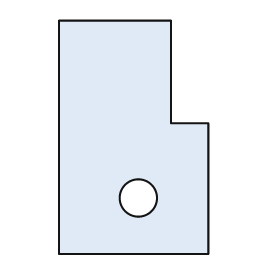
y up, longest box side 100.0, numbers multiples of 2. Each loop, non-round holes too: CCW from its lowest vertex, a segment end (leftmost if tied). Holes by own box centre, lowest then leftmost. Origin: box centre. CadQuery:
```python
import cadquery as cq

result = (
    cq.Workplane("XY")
    .moveTo(-32.0, -50.0)
    .lineTo(32.0, -50.0)
    .lineTo(32.0, 6.0)
    .lineTo(16.0, 6.0)
    .lineTo(16.0, 50.0)
    .lineTo(-32.0, 50.0)
    .close()
    .moveTo(2.0, -26.0)
    .circle(8.0)
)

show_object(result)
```